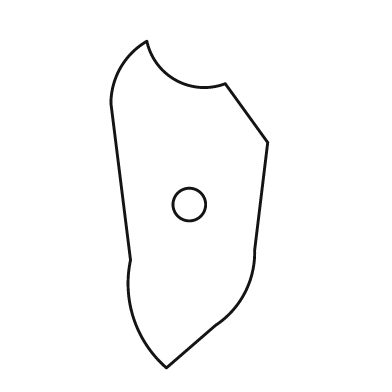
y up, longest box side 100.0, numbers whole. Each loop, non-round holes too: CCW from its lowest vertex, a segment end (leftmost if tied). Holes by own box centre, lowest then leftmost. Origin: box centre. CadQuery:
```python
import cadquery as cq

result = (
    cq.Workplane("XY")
    .moveTo(-7.0, -50.0)
    .lineTo(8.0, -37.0)
    .threePointArc((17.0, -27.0), (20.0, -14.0))
    .lineTo(24.0, 19.0)
    .lineTo(11.0, 37.0)
    .threePointArc((-4.0, 38.0), (-13.0, 50.0))
    .threePointArc((-21.0, 42.0), (-24.0, 31.0))
    .lineTo(-18.0, -17.0)
    .threePointArc((-17.0, -35.0), (-7.0, -50.0))
    .close()
    .moveTo(0.0, 0.0)
    .circle(5.0)
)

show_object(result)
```